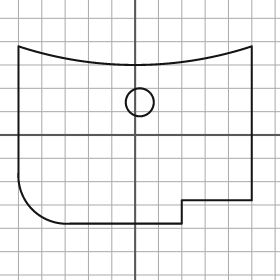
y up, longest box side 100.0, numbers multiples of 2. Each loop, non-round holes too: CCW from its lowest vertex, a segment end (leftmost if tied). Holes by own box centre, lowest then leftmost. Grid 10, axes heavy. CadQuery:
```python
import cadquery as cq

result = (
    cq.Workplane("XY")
    .moveTo(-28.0, -38.0)
    .lineTo(20.0, -38.0)
    .lineTo(20.0, -28.0)
    .lineTo(50.0, -28.0)
    .lineTo(50.0, 38.0)
    .threePointArc((0.0, 30.0), (-50.0, 38.0))
    .lineTo(-50.0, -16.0)
    .threePointArc((-44.0, -32.0), (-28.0, -38.0))
    .close()
    .moveTo(2.0, 14.0)
    .circle(6.0)
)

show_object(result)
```